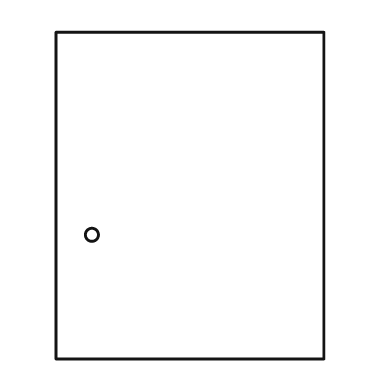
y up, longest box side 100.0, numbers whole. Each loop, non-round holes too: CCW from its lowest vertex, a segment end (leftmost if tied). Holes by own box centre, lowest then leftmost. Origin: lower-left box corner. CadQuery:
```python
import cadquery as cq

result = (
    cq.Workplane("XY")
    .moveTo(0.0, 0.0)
    .lineTo(82.0, 0.0)
    .lineTo(82.0, 100.0)
    .lineTo(0.0, 100.0)
    .close()
    .moveTo(11.0, 38.0)
    .circle(2.0)
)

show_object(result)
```